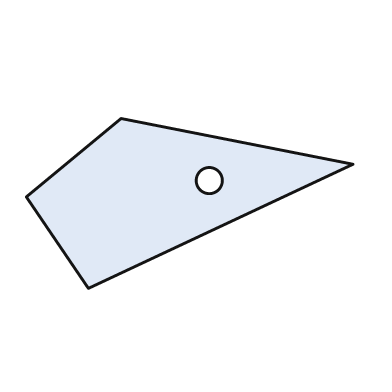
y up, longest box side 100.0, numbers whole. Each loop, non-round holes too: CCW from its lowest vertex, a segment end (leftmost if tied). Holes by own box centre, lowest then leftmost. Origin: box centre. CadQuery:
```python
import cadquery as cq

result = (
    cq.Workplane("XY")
    .moveTo(-31.0, -26.0)
    .lineTo(50.0, 12.0)
    .lineTo(-21.0, 26.0)
    .lineTo(-50.0, 2.0)
    .close()
    .moveTo(6.0, 7.0)
    .circle(4.0)
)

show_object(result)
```